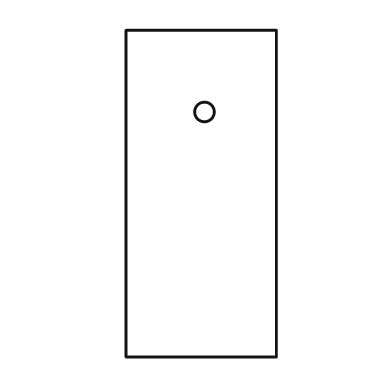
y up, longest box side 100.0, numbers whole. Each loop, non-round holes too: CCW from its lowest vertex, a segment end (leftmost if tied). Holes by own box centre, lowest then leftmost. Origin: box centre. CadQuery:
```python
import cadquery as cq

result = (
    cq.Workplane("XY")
    .moveTo(-23.0, -50.0)
    .lineTo(23.0, -50.0)
    .lineTo(23.0, 50.0)
    .lineTo(-23.0, 50.0)
    .close()
    .moveTo(1.0, 25.0)
    .circle(3.0)
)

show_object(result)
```